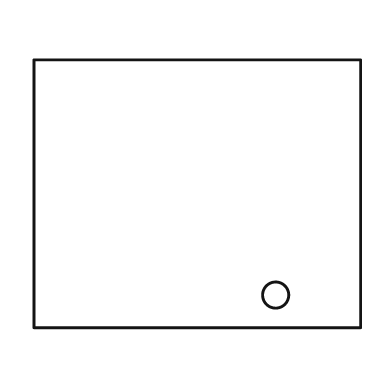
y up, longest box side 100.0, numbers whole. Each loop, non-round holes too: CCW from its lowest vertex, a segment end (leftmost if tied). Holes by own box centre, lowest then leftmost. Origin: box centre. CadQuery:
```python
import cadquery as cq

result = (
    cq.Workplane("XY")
    .moveTo(-50.0, -41.0)
    .lineTo(50.0, -41.0)
    .lineTo(50.0, 41.0)
    .lineTo(-50.0, 41.0)
    .close()
    .moveTo(24.0, -31.0)
    .circle(4.0)
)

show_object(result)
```